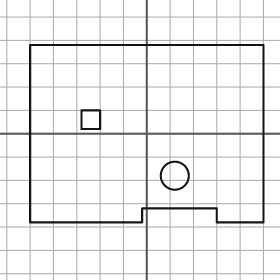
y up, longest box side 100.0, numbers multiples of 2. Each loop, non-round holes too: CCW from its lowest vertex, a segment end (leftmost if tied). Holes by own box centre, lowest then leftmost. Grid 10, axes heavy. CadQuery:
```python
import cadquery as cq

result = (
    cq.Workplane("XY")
    .moveTo(-50.0, -38.0)
    .lineTo(-2.0, -38.0)
    .lineTo(-2.0, -32.0)
    .lineTo(30.0, -32.0)
    .lineTo(30.0, -38.0)
    .lineTo(50.0, -38.0)
    .lineTo(50.0, 38.0)
    .lineTo(-50.0, 38.0)
    .close()
    .moveTo(12.0, -18.0)
    .circle(6.0)
    .moveTo(-28.0, 2.0)
    .lineTo(-20.0, 2.0)
    .lineTo(-20.0, 10.0)
    .lineTo(-28.0, 10.0)
    .close()
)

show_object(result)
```